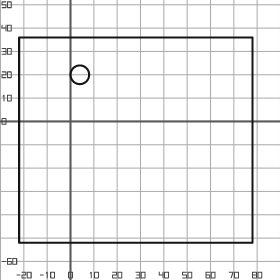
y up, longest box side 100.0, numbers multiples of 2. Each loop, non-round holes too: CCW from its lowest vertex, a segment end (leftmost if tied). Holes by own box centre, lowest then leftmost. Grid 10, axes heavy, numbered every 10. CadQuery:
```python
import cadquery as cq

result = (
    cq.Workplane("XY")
    .moveTo(-22.0, -52.0)
    .lineTo(78.0, -52.0)
    .lineTo(78.0, 36.0)
    .lineTo(-22.0, 36.0)
    .close()
    .moveTo(4.0, 20.0)
    .circle(4.0)
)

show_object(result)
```